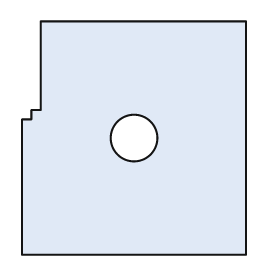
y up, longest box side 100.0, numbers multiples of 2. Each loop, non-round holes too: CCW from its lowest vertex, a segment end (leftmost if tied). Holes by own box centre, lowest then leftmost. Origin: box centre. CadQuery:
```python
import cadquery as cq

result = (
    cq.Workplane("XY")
    .moveTo(-48.0, -50.0)
    .lineTo(48.0, -50.0)
    .lineTo(48.0, 50.0)
    .lineTo(-40.0, 50.0)
    .lineTo(-40.0, 12.0)
    .lineTo(-44.0, 12.0)
    .lineTo(-44.0, 8.0)
    .lineTo(-48.0, 8.0)
    .close()
    .moveTo(0.0, 0.0)
    .circle(10.0)
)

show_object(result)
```